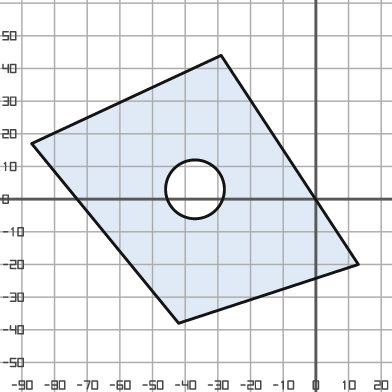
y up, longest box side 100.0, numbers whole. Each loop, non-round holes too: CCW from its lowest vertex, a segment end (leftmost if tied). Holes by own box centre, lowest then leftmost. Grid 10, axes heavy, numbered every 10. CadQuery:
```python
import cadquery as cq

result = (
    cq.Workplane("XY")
    .moveTo(-42.0, -38.0)
    .lineTo(13.0, -20.0)
    .lineTo(-29.0, 44.0)
    .lineTo(-87.0, 17.0)
    .close()
    .moveTo(-37.0, 3.0)
    .circle(9.0)
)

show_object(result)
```